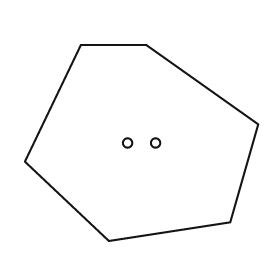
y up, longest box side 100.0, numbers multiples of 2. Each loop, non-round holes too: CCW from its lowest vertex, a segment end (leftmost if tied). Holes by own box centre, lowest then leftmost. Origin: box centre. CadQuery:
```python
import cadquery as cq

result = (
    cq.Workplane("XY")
    .moveTo(-14.0, -42.0)
    .lineTo(38.0, -34.0)
    .lineTo(50.0, 8.0)
    .lineTo(2.0, 42.0)
    .lineTo(-26.0, 42.0)
    .lineTo(-50.0, -8.0)
    .close()
    .moveTo(-6.0, 0.0)
    .circle(2.0)
    .moveTo(6.0, 0.0)
    .circle(2.0)
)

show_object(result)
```